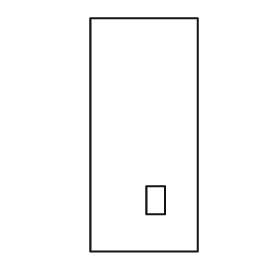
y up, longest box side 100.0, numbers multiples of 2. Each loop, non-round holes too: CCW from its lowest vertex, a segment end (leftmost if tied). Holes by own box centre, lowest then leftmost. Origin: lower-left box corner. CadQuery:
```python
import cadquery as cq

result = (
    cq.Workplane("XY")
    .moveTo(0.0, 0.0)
    .lineTo(46.0, 0.0)
    .lineTo(46.0, 100.0)
    .lineTo(0.0, 100.0)
    .close()
    .moveTo(24.0, 16.0)
    .lineTo(32.0, 16.0)
    .lineTo(32.0, 28.0)
    .lineTo(24.0, 28.0)
    .close()
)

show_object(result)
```